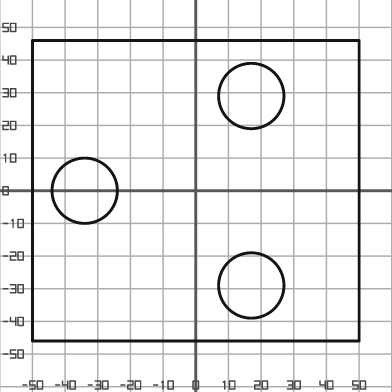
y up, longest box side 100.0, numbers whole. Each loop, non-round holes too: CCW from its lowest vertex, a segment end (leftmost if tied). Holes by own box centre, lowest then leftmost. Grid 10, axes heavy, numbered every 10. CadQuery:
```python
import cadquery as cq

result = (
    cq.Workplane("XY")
    .moveTo(-50.0, -46.0)
    .lineTo(50.0, -46.0)
    .lineTo(50.0, 46.0)
    .lineTo(-50.0, 46.0)
    .close()
    .moveTo(17.0, -29.0)
    .circle(10.0)
    .moveTo(-34.0, 0.0)
    .circle(10.0)
    .moveTo(17.0, 29.0)
    .circle(10.0)
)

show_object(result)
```